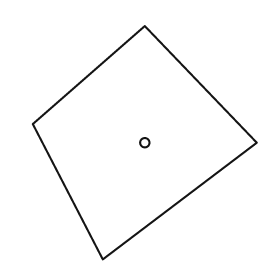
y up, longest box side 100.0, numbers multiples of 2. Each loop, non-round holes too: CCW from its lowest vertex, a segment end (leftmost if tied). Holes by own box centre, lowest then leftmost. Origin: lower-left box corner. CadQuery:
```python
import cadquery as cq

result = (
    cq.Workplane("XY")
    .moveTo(30.0, 0.0)
    .lineTo(96.0, 50.0)
    .lineTo(48.0, 100.0)
    .lineTo(0.0, 58.0)
    .close()
    .moveTo(48.0, 50.0)
    .circle(2.0)
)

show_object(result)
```